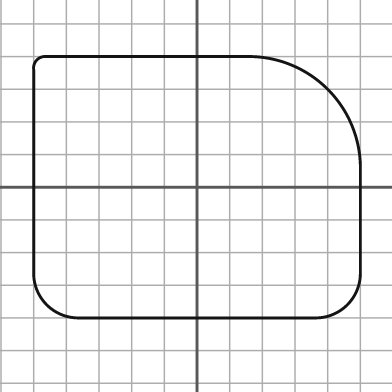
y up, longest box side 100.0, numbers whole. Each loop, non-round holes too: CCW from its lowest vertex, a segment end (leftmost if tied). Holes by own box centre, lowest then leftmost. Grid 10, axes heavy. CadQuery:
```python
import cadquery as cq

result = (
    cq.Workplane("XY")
    .moveTo(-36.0, -40.0)
    .lineTo(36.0, -40.0)
    .threePointArc((46.0, -36.0), (50.0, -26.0))
    .lineTo(50.0, 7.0)
    .threePointArc((40.0, 30.0), (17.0, 40.0))
    .lineTo(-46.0, 40.0)
    .threePointArc((-49.0, 39.0), (-50.0, 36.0))
    .lineTo(-50.0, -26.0)
    .threePointArc((-46.0, -36.0), (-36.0, -40.0))
    .close()
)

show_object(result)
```